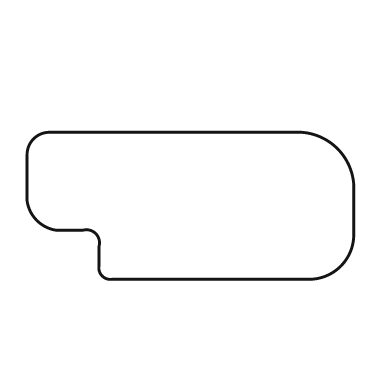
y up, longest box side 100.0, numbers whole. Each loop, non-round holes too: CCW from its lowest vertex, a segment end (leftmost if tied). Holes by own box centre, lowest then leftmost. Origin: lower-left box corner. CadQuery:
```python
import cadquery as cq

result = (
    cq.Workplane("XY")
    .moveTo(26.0, 0.0)
    .lineTo(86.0, 0.0)
    .threePointArc((96.0, 4.0), (100.0, 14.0))
    .lineTo(100.0, 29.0)
    .threePointArc((95.0, 40.0), (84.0, 45.0))
    .lineTo(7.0, 45.0)
    .threePointArc((2.0, 43.0), (0.0, 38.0))
    .lineTo(0.0, 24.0)
    .threePointArc((3.0, 18.0), (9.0, 15.0))
    .lineTo(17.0, 15.0)
    .threePointArc((21.0, 14.0), (22.0, 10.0))
    .lineTo(22.0, 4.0)
    .threePointArc((23.0, 1.0), (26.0, 0.0))
    .close()
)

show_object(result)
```